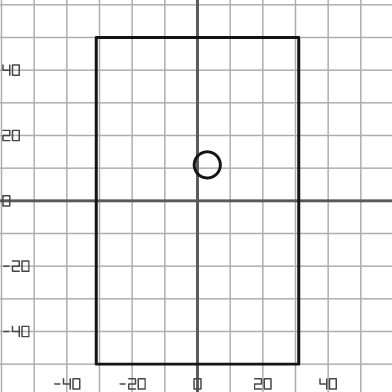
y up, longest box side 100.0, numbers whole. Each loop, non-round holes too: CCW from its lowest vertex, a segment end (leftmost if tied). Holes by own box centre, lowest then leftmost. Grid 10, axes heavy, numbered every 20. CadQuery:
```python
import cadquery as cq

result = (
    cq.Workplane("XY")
    .moveTo(-31.0, -50.0)
    .lineTo(31.0, -50.0)
    .lineTo(31.0, 50.0)
    .lineTo(-31.0, 50.0)
    .close()
    .moveTo(3.0, 11.0)
    .circle(4.0)
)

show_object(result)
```